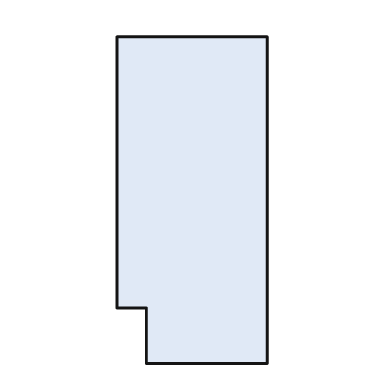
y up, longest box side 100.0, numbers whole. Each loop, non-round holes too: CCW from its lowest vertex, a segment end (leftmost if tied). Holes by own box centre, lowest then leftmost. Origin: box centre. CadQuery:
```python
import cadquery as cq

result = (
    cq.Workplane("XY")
    .moveTo(-14.0, -50.0)
    .lineTo(23.0, -50.0)
    .lineTo(23.0, 50.0)
    .lineTo(-23.0, 50.0)
    .lineTo(-23.0, -33.0)
    .lineTo(-14.0, -33.0)
    .close()
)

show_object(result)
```